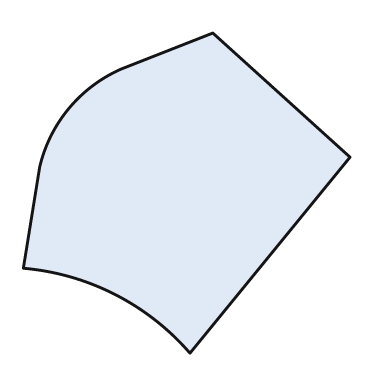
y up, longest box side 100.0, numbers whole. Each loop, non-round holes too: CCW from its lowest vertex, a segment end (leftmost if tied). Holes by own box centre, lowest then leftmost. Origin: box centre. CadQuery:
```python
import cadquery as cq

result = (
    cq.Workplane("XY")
    .moveTo(1.0, -49.0)
    .lineTo(50.0, 11.0)
    .lineTo(8.0, 49.0)
    .lineTo(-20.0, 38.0)
    .threePointArc((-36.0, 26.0), (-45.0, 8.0))
    .lineTo(-50.0, -23.0)
    .threePointArc((-22.0, -31.0), (1.0, -49.0))
    .close()
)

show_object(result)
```